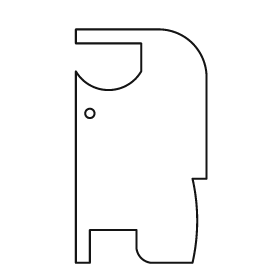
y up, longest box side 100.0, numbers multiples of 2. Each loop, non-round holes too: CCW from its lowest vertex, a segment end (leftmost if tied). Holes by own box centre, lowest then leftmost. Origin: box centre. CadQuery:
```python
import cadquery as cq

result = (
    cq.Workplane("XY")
    .moveTo(-28.0, -50.0)
    .lineTo(-22.0, -50.0)
    .lineTo(-22.0, -36.0)
    .lineTo(-2.0, -36.0)
    .lineTo(-2.0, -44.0)
    .threePointArc((0.0, -48.0), (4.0, -50.0))
    .lineTo(22.0, -50.0)
    .threePointArc((24.0, -32.0), (22.0, -14.0))
    .lineTo(28.0, -14.0)
    .lineTo(28.0, 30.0)
    .threePointArc((22.0, 44.0), (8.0, 50.0))
    .lineTo(-28.0, 50.0)
    .lineTo(-28.0, 44.0)
    .lineTo(0.0, 44.0)
    .lineTo(0.0, 32.0)
    .threePointArc((-14.0, 24.0), (-28.0, 32.0))
    .close()
    .moveTo(-22.0, 14.0)
    .circle(2.0)
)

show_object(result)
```